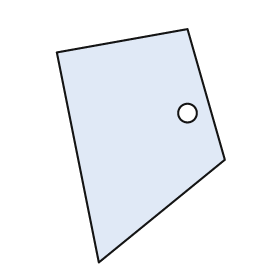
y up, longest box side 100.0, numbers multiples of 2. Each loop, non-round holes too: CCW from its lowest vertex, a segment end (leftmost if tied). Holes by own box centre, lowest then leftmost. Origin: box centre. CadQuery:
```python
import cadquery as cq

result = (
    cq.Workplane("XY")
    .moveTo(-18.0, -50.0)
    .lineTo(36.0, -6.0)
    .lineTo(20.0, 50.0)
    .lineTo(-36.0, 40.0)
    .close()
    .moveTo(20.0, 14.0)
    .circle(4.0)
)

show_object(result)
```